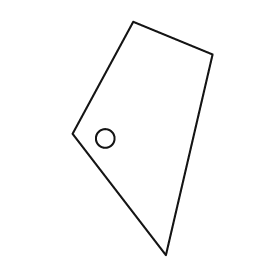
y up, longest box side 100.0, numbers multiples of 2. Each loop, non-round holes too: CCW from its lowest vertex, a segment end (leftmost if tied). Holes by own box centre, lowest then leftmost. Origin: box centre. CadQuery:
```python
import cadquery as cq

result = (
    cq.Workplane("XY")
    .moveTo(10.0, -50.0)
    .lineTo(30.0, 36.0)
    .lineTo(-4.0, 50.0)
    .lineTo(-30.0, 2.0)
    .close()
    .moveTo(-16.0, 0.0)
    .circle(4.0)
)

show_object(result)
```